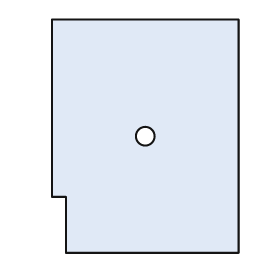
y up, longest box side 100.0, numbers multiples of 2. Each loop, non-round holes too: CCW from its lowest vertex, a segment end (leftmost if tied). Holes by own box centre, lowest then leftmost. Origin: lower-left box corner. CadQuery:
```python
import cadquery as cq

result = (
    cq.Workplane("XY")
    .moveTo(6.0, 0.0)
    .lineTo(80.0, 0.0)
    .lineTo(80.0, 100.0)
    .lineTo(0.0, 100.0)
    .lineTo(0.0, 24.0)
    .lineTo(6.0, 24.0)
    .close()
    .moveTo(40.0, 50.0)
    .circle(4.0)
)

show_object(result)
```